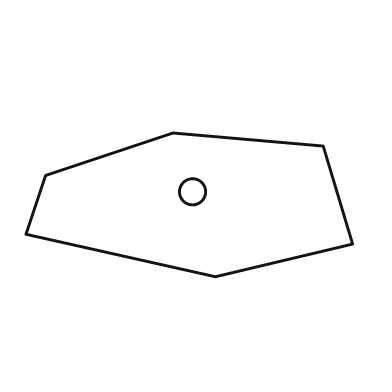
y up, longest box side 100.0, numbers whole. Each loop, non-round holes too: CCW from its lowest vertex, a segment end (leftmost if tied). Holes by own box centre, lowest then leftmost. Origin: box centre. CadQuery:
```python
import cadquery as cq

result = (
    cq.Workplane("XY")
    .moveTo(8.0, -22.0)
    .lineTo(50.0, -12.0)
    .lineTo(41.0, 18.0)
    .lineTo(-5.0, 22.0)
    .lineTo(-44.0, 9.0)
    .lineTo(-50.0, -9.0)
    .close()
    .moveTo(1.0, 4.0)
    .circle(4.0)
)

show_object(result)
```